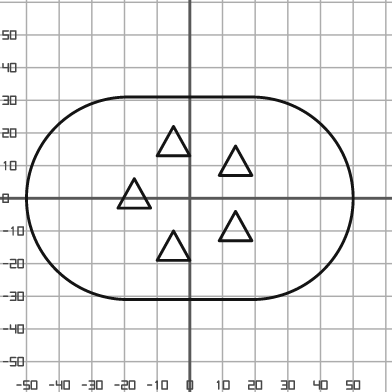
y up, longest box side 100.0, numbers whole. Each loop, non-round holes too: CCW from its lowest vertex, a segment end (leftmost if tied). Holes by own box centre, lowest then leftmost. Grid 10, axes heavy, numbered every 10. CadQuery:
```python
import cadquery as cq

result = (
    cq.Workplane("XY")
    .moveTo(-19.0, -31.0)
    .lineTo(19.0, -31.0)
    .threePointArc((50.0, 0.0), (19.0, 31.0))
    .lineTo(-19.0, 31.0)
    .threePointArc((-50.0, 0.0), (-19.0, -31.0))
    .close()
    .moveTo(-10.0, -19.0)
    .lineTo(0.0, -19.0)
    .lineTo(-5.0, -10.0)
    .close()
    .moveTo(9.0, -13.0)
    .lineTo(19.0, -13.0)
    .lineTo(14.0, -4.0)
    .close()
    .moveTo(-22.0, -3.0)
    .lineTo(-12.0, -3.0)
    .lineTo(-17.0, 6.0)
    .close()
    .moveTo(9.0, 7.0)
    .lineTo(19.0, 7.0)
    .lineTo(14.0, 16.0)
    .close()
    .moveTo(-10.0, 13.0)
    .lineTo(0.0, 13.0)
    .lineTo(-5.0, 22.0)
    .close()
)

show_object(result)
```